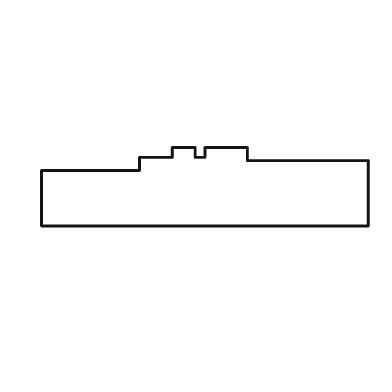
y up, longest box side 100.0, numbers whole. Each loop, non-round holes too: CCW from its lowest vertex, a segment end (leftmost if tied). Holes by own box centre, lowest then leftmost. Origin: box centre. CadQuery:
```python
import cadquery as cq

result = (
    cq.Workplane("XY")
    .moveTo(-50.0, -12.0)
    .lineTo(50.0, -12.0)
    .lineTo(50.0, 8.0)
    .lineTo(13.0, 8.0)
    .lineTo(13.0, 12.0)
    .lineTo(0.0, 12.0)
    .lineTo(0.0, 9.0)
    .lineTo(-3.0, 9.0)
    .lineTo(-3.0, 12.0)
    .lineTo(-10.0, 12.0)
    .lineTo(-10.0, 9.0)
    .lineTo(-20.0, 9.0)
    .lineTo(-20.0, 5.0)
    .lineTo(-50.0, 5.0)
    .close()
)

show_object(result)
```